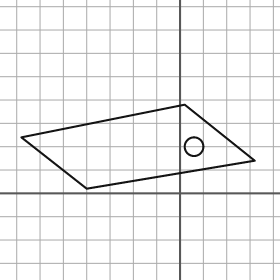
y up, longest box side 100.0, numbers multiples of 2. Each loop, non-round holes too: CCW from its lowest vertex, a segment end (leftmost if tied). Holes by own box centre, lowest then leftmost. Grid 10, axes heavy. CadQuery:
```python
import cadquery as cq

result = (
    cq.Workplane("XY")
    .moveTo(-40.0, 2.0)
    .lineTo(32.0, 14.0)
    .lineTo(2.0, 38.0)
    .lineTo(-68.0, 24.0)
    .close()
    .moveTo(6.0, 20.0)
    .circle(4.0)
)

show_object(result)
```